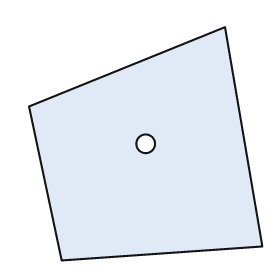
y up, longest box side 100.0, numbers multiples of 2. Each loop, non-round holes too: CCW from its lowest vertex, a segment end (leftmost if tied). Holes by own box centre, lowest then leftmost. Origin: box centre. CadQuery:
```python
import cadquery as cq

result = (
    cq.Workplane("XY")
    .moveTo(-36.0, -50.0)
    .lineTo(50.0, -44.0)
    .lineTo(34.0, 50.0)
    .lineTo(-50.0, 16.0)
    .close()
    .moveTo(0.0, 0.0)
    .circle(4.0)
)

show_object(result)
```